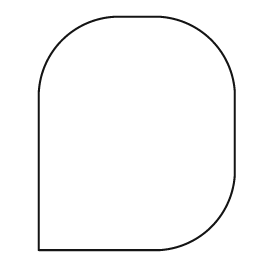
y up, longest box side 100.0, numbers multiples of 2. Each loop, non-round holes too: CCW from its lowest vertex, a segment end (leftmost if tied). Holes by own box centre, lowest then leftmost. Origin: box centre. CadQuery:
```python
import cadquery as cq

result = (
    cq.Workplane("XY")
    .moveTo(-42.0, -50.0)
    .lineTo(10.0, -50.0)
    .threePointArc((32.0, -40.0), (42.0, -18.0))
    .lineTo(42.0, 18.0)
    .threePointArc((32.0, 40.0), (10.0, 50.0))
    .lineTo(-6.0, 50.0)
    .threePointArc((-32.0, 40.0), (-42.0, 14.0))
    .close()
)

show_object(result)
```